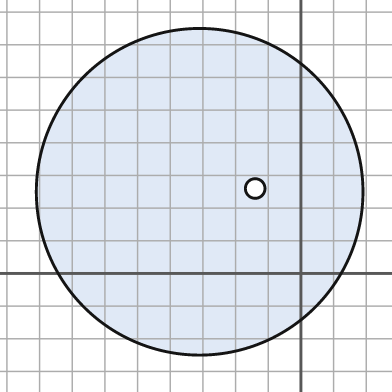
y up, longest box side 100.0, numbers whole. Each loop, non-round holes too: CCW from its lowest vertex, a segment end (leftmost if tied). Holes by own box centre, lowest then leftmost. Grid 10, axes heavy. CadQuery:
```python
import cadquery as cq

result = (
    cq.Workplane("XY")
    .moveTo(-31.0, 25.0)
    .circle(50.0)
    .moveTo(-14.0, 26.0)
    .circle(3.0)
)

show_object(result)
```